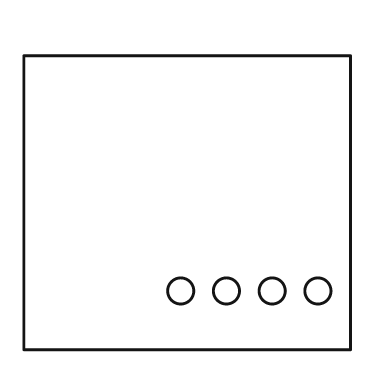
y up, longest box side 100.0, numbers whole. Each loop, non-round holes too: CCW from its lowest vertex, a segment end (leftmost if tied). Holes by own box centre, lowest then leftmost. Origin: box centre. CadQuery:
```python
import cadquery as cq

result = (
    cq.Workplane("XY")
    .moveTo(-50.0, -45.0)
    .lineTo(50.0, -45.0)
    .lineTo(50.0, 45.0)
    .lineTo(-50.0, 45.0)
    .close()
    .moveTo(-2.0, -27.0)
    .circle(4.0)
    .moveTo(12.0, -27.0)
    .circle(4.0)
    .moveTo(26.0, -27.0)
    .circle(4.0)
    .moveTo(40.0, -27.0)
    .circle(4.0)
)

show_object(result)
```